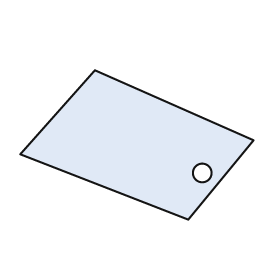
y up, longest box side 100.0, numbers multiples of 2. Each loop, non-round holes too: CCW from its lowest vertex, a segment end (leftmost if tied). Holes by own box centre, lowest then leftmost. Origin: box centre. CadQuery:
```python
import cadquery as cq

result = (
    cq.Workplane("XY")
    .moveTo(22.0, -32.0)
    .lineTo(50.0, 2.0)
    .lineTo(-18.0, 32.0)
    .lineTo(-50.0, -4.0)
    .close()
    .moveTo(28.0, -12.0)
    .circle(4.0)
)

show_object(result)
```